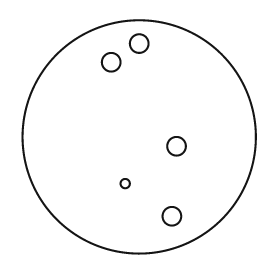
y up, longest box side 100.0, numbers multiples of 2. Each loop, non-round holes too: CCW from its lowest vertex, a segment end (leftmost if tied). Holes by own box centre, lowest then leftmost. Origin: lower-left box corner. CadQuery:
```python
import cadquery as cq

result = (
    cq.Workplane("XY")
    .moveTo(50.0, 50.0)
    .circle(50.0)
    .moveTo(64.0, 16.0)
    .circle(4.0)
    .moveTo(44.0, 30.0)
    .circle(2.0)
    .moveTo(66.0, 46.0)
    .circle(4.0)
    .moveTo(38.0, 82.0)
    .circle(4.0)
    .moveTo(50.0, 90.0)
    .circle(4.0)
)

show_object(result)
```